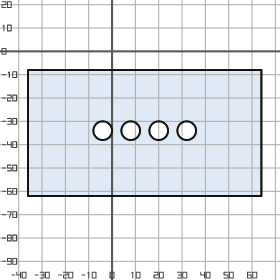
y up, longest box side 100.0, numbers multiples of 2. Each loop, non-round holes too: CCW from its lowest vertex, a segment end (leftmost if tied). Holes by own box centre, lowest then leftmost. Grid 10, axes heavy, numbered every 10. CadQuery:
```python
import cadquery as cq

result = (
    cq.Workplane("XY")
    .moveTo(-36.0, -62.0)
    .lineTo(64.0, -62.0)
    .lineTo(64.0, -8.0)
    .lineTo(-36.0, -8.0)
    .close()
    .moveTo(-4.0, -34.0)
    .circle(4.0)
    .moveTo(8.0, -34.0)
    .circle(4.0)
    .moveTo(20.0, -34.0)
    .circle(4.0)
    .moveTo(32.0, -34.0)
    .circle(4.0)
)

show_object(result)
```